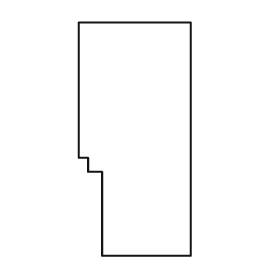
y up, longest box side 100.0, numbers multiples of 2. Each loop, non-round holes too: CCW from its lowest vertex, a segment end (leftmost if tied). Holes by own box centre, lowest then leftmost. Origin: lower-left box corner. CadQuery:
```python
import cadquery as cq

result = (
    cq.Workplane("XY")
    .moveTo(10.0, 0.0)
    .lineTo(48.0, 0.0)
    .lineTo(48.0, 100.0)
    .lineTo(0.0, 100.0)
    .lineTo(0.0, 42.0)
    .lineTo(4.0, 42.0)
    .lineTo(4.0, 36.0)
    .lineTo(10.0, 36.0)
    .close()
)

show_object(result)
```